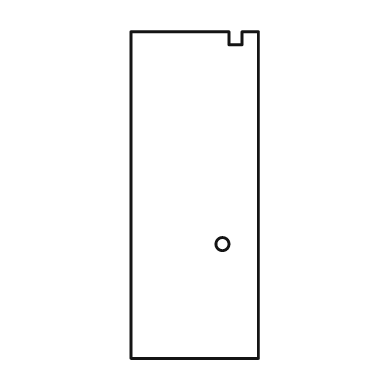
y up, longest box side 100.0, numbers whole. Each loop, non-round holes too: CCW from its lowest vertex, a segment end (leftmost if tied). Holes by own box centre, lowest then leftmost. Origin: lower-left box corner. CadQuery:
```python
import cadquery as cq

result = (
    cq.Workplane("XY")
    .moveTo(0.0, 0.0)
    .lineTo(39.0, 0.0)
    .lineTo(39.0, 100.0)
    .lineTo(34.0, 100.0)
    .lineTo(34.0, 96.0)
    .lineTo(30.0, 96.0)
    .lineTo(30.0, 100.0)
    .lineTo(0.0, 100.0)
    .close()
    .moveTo(28.0, 35.0)
    .circle(2.0)
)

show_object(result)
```